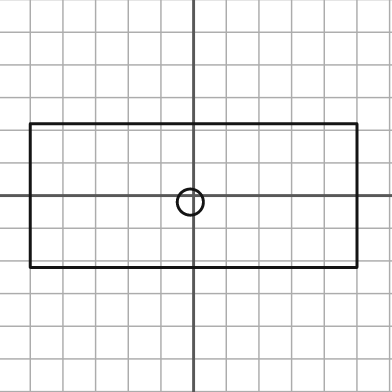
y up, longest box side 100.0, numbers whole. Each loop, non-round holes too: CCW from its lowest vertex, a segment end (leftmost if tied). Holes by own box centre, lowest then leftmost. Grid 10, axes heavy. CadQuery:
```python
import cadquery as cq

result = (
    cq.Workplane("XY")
    .moveTo(-50.0, -22.0)
    .lineTo(50.0, -22.0)
    .lineTo(50.0, 22.0)
    .lineTo(-50.0, 22.0)
    .close()
    .moveTo(-1.0, -2.0)
    .circle(4.0)
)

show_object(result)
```